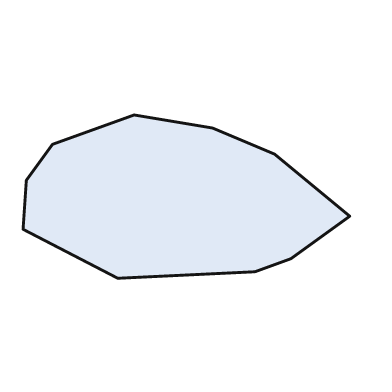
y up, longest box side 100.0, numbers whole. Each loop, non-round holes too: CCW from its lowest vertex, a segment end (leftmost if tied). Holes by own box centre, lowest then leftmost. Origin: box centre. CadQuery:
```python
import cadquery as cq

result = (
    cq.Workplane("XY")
    .moveTo(-21.0, -25.0)
    .lineTo(21.0, -23.0)
    .lineTo(32.0, -19.0)
    .lineTo(50.0, -6.0)
    .lineTo(27.0, 13.0)
    .lineTo(8.0, 21.0)
    .lineTo(-16.0, 25.0)
    .lineTo(-41.0, 16.0)
    .lineTo(-49.0, 5.0)
    .lineTo(-50.0, -10.0)
    .close()
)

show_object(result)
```